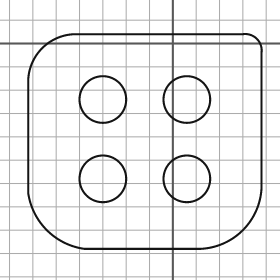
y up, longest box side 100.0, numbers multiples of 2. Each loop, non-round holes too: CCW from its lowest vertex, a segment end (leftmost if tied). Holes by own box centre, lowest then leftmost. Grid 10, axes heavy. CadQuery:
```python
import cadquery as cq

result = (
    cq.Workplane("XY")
    .moveTo(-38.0, -88.0)
    .lineTo(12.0, -88.0)
    .threePointArc((30.0, -80.0), (38.0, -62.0))
    .lineTo(38.0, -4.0)
    .threePointArc((36.0, 2.0), (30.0, 4.0))
    .lineTo(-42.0, 4.0)
    .threePointArc((-56.0, -2.0), (-62.0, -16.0))
    .lineTo(-62.0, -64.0)
    .threePointArc((-54.0, -80.0), (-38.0, -88.0))
    .close()
    .moveTo(-30.0, -58.0)
    .circle(10.0)
    .moveTo(6.0, -58.0)
    .circle(10.0)
    .moveTo(-30.0, -24.0)
    .circle(10.0)
    .moveTo(6.0, -24.0)
    .circle(10.0)
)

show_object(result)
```